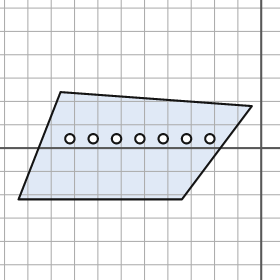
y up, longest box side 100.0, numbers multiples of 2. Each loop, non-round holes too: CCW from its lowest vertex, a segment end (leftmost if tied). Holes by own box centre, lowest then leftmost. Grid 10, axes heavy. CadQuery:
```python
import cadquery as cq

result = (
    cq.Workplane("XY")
    .moveTo(-104.0, -22.0)
    .lineTo(-34.0, -22.0)
    .lineTo(-4.0, 18.0)
    .lineTo(-86.0, 24.0)
    .close()
    .moveTo(-82.0, 4.0)
    .circle(2.0)
    .moveTo(-72.0, 4.0)
    .circle(2.0)
    .moveTo(-62.0, 4.0)
    .circle(2.0)
    .moveTo(-52.0, 4.0)
    .circle(2.0)
    .moveTo(-42.0, 4.0)
    .circle(2.0)
    .moveTo(-32.0, 4.0)
    .circle(2.0)
    .moveTo(-22.0, 4.0)
    .circle(2.0)
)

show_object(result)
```